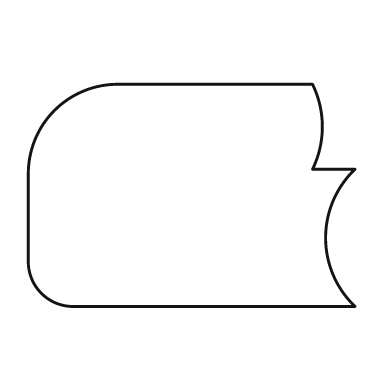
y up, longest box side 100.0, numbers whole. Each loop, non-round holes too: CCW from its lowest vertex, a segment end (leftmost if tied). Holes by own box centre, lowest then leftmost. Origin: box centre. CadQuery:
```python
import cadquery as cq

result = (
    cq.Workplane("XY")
    .moveTo(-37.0, -34.0)
    .lineTo(50.0, -34.0)
    .threePointArc((41.0, -13.0), (50.0, 8.0))
    .lineTo(37.0, 8.0)
    .threePointArc((40.0, 21.0), (37.0, 34.0))
    .lineTo(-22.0, 34.0)
    .threePointArc((-42.0, 26.0), (-50.0, 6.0))
    .lineTo(-50.0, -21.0)
    .threePointArc((-46.0, -30.0), (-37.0, -34.0))
    .close()
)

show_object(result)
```